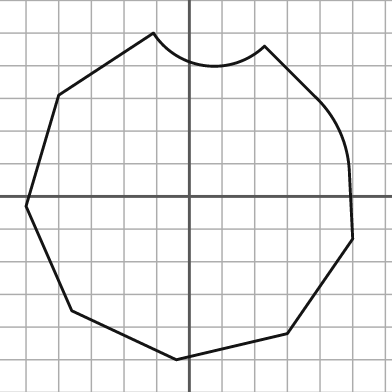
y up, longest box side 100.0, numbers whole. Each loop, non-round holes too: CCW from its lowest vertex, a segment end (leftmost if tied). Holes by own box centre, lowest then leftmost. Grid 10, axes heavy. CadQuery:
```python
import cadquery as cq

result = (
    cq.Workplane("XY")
    .moveTo(-4.0, -50.0)
    .lineTo(30.0, -42.0)
    .lineTo(50.0, -13.0)
    .lineTo(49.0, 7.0)
    .threePointArc((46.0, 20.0), (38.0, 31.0))
    .lineTo(23.0, 46.0)
    .threePointArc((5.0, 40.0), (-11.0, 50.0))
    .lineTo(-40.0, 31.0)
    .lineTo(-50.0, -3.0)
    .lineTo(-36.0, -35.0)
    .close()
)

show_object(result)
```